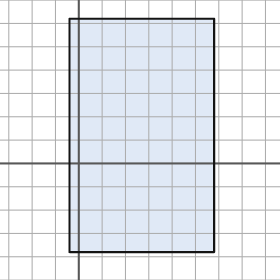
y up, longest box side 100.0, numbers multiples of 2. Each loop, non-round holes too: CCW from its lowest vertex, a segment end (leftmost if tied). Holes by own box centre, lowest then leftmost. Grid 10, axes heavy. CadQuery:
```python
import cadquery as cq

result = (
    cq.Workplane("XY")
    .moveTo(-4.0, -38.0)
    .lineTo(58.0, -38.0)
    .lineTo(58.0, 62.0)
    .lineTo(-4.0, 62.0)
    .close()
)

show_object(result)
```